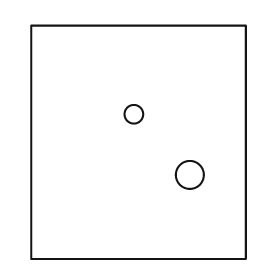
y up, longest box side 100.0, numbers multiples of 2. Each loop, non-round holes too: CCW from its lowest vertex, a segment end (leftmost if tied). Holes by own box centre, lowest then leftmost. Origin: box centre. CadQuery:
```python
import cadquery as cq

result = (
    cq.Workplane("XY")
    .moveTo(-46.0, -50.0)
    .lineTo(46.0, -50.0)
    .lineTo(46.0, 50.0)
    .lineTo(-46.0, 50.0)
    .close()
    .moveTo(22.0, -14.0)
    .circle(6.0)
    .moveTo(-2.0, 12.0)
    .circle(4.0)
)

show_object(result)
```